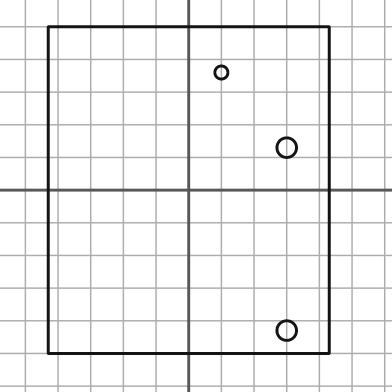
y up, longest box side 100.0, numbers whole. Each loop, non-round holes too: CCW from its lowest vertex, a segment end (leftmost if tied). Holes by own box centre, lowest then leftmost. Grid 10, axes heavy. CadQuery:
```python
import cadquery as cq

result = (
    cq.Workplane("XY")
    .moveTo(-43.0, -50.0)
    .lineTo(43.0, -50.0)
    .lineTo(43.0, 50.0)
    .lineTo(-43.0, 50.0)
    .close()
    .moveTo(30.0, -43.0)
    .circle(3.0)
    .moveTo(30.0, 13.0)
    .circle(3.0)
    .moveTo(10.0, 36.0)
    .circle(2.0)
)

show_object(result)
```